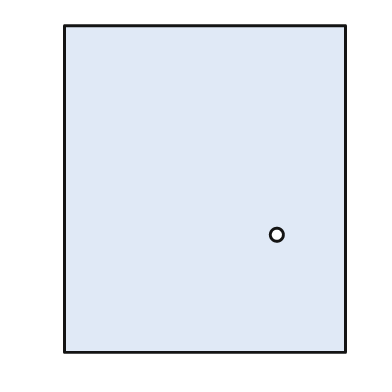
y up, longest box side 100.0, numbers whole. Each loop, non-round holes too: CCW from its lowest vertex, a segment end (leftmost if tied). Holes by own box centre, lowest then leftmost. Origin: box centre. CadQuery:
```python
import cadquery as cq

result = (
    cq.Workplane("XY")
    .moveTo(-43.0, -50.0)
    .lineTo(43.0, -50.0)
    .lineTo(43.0, 50.0)
    .lineTo(-43.0, 50.0)
    .close()
    .moveTo(22.0, -14.0)
    .circle(2.0)
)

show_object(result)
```